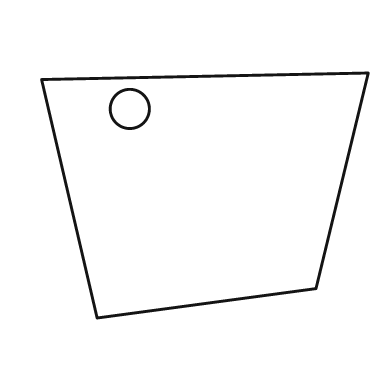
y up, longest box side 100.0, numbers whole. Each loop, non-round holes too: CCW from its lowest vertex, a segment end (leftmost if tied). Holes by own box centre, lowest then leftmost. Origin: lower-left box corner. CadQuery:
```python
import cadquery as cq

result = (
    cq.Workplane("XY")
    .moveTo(17.0, 0.0)
    .lineTo(84.0, 9.0)
    .lineTo(100.0, 75.0)
    .lineTo(0.0, 73.0)
    .close()
    .moveTo(27.0, 64.0)
    .circle(6.0)
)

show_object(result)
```